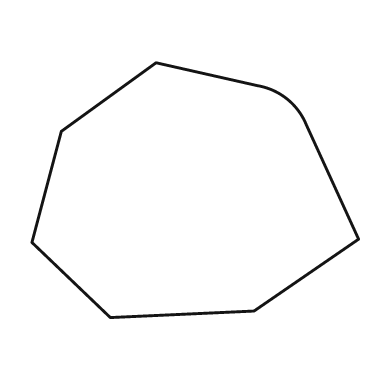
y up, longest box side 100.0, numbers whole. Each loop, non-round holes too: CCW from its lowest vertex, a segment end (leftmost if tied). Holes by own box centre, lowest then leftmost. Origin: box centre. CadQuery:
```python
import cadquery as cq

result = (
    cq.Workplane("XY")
    .moveTo(-26.0, -39.0)
    .lineTo(18.0, -37.0)
    .lineTo(50.0, -15.0)
    .lineTo(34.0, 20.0)
    .threePointArc((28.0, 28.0), (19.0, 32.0))
    .lineTo(-12.0, 39.0)
    .lineTo(-41.0, 18.0)
    .lineTo(-50.0, -16.0)
    .close()
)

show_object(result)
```